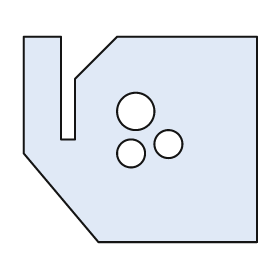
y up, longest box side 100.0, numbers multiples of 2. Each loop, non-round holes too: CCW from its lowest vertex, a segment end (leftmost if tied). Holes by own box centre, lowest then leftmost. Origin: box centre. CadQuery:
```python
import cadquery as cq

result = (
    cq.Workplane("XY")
    .moveTo(-18.0, -44.0)
    .lineTo(50.0, -44.0)
    .lineTo(50.0, 44.0)
    .lineTo(-10.0, 44.0)
    .lineTo(-28.0, 26.0)
    .lineTo(-28.0, 0.0)
    .lineTo(-34.0, 0.0)
    .lineTo(-34.0, 44.0)
    .lineTo(-50.0, 44.0)
    .lineTo(-50.0, -6.0)
    .close()
    .moveTo(-4.0, -6.0)
    .circle(6.0)
    .moveTo(12.0, -2.0)
    .circle(6.0)
    .moveTo(-2.0, 12.0)
    .circle(8.0)
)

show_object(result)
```